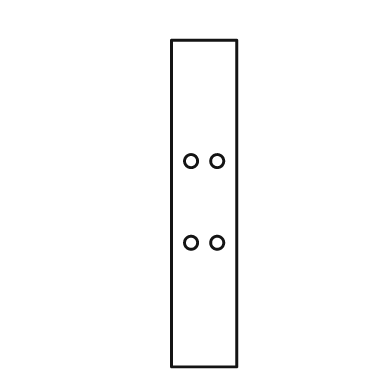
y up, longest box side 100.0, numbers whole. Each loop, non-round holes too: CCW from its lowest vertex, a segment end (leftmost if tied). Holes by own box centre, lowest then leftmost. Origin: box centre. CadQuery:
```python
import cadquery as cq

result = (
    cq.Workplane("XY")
    .moveTo(-10.0, -50.0)
    .lineTo(10.0, -50.0)
    .lineTo(10.0, 50.0)
    .lineTo(-10.0, 50.0)
    .close()
    .moveTo(-4.0, -12.0)
    .circle(2.0)
    .moveTo(4.0, -12.0)
    .circle(2.0)
    .moveTo(-4.0, 13.0)
    .circle(2.0)
    .moveTo(4.0, 13.0)
    .circle(2.0)
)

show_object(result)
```